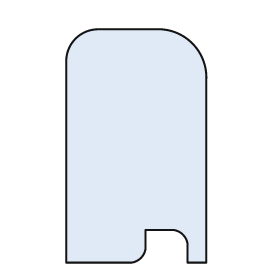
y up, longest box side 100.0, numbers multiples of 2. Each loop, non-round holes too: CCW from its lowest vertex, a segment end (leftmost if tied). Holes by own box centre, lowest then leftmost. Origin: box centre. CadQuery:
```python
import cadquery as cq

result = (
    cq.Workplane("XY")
    .moveTo(-30.0, -50.0)
    .lineTo(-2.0, -50.0)
    .threePointArc((2.0, -48.0), (4.0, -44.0))
    .lineTo(4.0, -36.0)
    .lineTo(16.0, -36.0)
    .threePointArc((20.0, -38.0), (22.0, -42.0))
    .lineTo(22.0, -50.0)
    .lineTo(30.0, -50.0)
    .lineTo(30.0, 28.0)
    .threePointArc((24.0, 44.0), (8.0, 50.0))
    .lineTo(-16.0, 50.0)
    .threePointArc((-26.0, 46.0), (-30.0, 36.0))
    .close()
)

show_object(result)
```